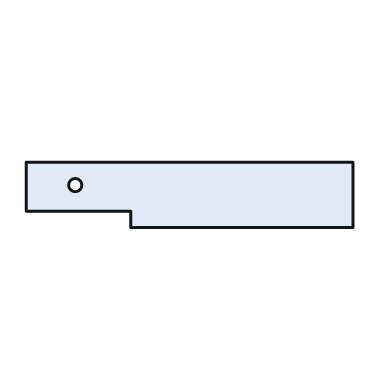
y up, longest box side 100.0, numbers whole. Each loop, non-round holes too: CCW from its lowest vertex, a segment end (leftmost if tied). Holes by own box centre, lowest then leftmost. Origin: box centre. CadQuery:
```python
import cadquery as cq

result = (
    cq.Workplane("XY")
    .moveTo(-18.0, -10.0)
    .lineTo(50.0, -10.0)
    .lineTo(50.0, 10.0)
    .lineTo(-50.0, 10.0)
    .lineTo(-50.0, -5.0)
    .lineTo(-18.0, -5.0)
    .close()
    .moveTo(-35.0, 3.0)
    .circle(2.0)
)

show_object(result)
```